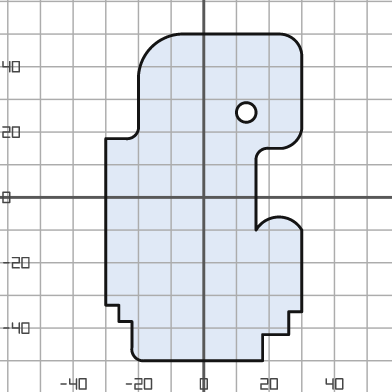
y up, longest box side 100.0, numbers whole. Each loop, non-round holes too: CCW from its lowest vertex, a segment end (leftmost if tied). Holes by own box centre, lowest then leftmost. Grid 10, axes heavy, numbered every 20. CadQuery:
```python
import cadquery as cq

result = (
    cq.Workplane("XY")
    .moveTo(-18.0, -50.0)
    .lineTo(18.0, -50.0)
    .lineTo(18.0, -42.0)
    .lineTo(26.0, -42.0)
    .lineTo(26.0, -35.0)
    .lineTo(30.0, -35.0)
    .lineTo(30.0, -10.0)
    .threePointArc((23.0, -6.0), (16.0, -10.0))
    .lineTo(16.0, 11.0)
    .threePointArc((17.0, 14.0), (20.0, 15.0))
    .lineTo(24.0, 15.0)
    .threePointArc((28.0, 17.0), (30.0, 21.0))
    .lineTo(30.0, 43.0)
    .threePointArc((28.0, 48.0), (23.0, 50.0))
    .lineTo(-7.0, 50.0)
    .threePointArc((-16.0, 46.0), (-20.0, 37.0))
    .lineTo(-20.0, 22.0)
    .threePointArc((-21.0, 19.0), (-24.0, 18.0))
    .lineTo(-30.0, 18.0)
    .lineTo(-30.0, -33.0)
    .lineTo(-26.0, -33.0)
    .lineTo(-26.0, -38.0)
    .lineTo(-22.0, -38.0)
    .lineTo(-22.0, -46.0)
    .threePointArc((-21.0, -49.0), (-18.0, -50.0))
    .close()
    .moveTo(13.0, 26.0)
    .circle(3.0)
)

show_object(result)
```